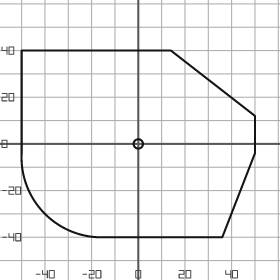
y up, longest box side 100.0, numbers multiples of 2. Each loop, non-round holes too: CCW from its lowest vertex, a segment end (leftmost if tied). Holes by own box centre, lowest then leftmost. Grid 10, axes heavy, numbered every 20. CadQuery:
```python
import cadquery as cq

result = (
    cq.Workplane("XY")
    .moveTo(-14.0, -40.0)
    .lineTo(36.0, -40.0)
    .lineTo(50.0, -4.0)
    .lineTo(50.0, 12.0)
    .lineTo(14.0, 40.0)
    .lineTo(-50.0, 40.0)
    .lineTo(-50.0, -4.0)
    .threePointArc((-40.0, -30.0), (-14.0, -40.0))
    .close()
    .moveTo(0.0, 0.0)
    .circle(2.0)
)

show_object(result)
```